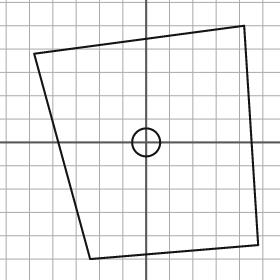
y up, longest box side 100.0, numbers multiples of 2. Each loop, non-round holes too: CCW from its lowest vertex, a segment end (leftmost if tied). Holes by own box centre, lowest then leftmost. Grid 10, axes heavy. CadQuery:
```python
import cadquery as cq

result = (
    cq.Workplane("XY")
    .moveTo(-24.0, -50.0)
    .lineTo(48.0, -44.0)
    .lineTo(42.0, 50.0)
    .lineTo(-48.0, 38.0)
    .close()
    .moveTo(0.0, 0.0)
    .circle(6.0)
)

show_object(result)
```